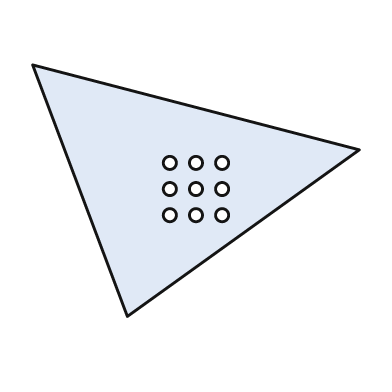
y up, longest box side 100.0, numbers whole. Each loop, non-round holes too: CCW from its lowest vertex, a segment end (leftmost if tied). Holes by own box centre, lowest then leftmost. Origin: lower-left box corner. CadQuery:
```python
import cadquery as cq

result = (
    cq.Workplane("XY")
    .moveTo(29.0, 0.0)
    .lineTo(100.0, 51.0)
    .lineTo(0.0, 77.0)
    .close()
    .moveTo(42.0, 31.0)
    .circle(2.0)
    .moveTo(50.0, 31.0)
    .circle(2.0)
    .moveTo(58.0, 31.0)
    .circle(2.0)
    .moveTo(42.0, 39.0)
    .circle(2.0)
    .moveTo(50.0, 39.0)
    .circle(2.0)
    .moveTo(58.0, 39.0)
    .circle(2.0)
    .moveTo(42.0, 47.0)
    .circle(2.0)
    .moveTo(50.0, 47.0)
    .circle(2.0)
    .moveTo(58.0, 47.0)
    .circle(2.0)
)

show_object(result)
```